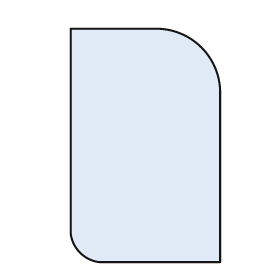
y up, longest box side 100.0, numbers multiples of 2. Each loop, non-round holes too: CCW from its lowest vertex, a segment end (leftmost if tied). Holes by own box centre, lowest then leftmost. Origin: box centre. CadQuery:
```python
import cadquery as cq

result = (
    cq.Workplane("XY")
    .moveTo(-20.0, -50.0)
    .lineTo(32.0, -50.0)
    .lineTo(32.0, 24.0)
    .threePointArc((24.0, 42.0), (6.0, 50.0))
    .lineTo(-32.0, 50.0)
    .lineTo(-32.0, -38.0)
    .threePointArc((-28.0, -46.0), (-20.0, -50.0))
    .close()
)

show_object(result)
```